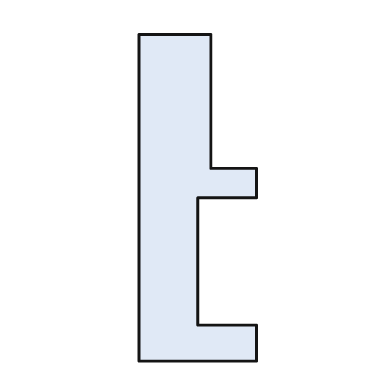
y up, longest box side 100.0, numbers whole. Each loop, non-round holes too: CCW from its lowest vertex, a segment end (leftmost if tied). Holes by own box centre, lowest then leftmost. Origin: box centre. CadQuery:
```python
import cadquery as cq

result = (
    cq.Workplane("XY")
    .moveTo(-18.0, -50.0)
    .lineTo(18.0, -50.0)
    .lineTo(18.0, -39.0)
    .lineTo(0.0, -39.0)
    .lineTo(0.0, 0.0)
    .lineTo(18.0, 0.0)
    .lineTo(18.0, 9.0)
    .lineTo(4.0, 9.0)
    .lineTo(4.0, 50.0)
    .lineTo(-18.0, 50.0)
    .close()
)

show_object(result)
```